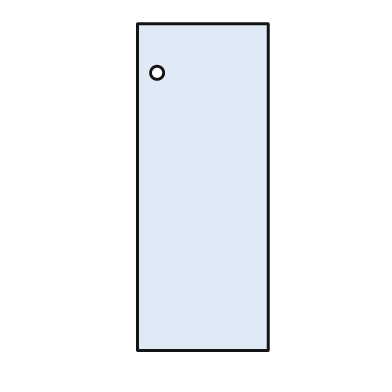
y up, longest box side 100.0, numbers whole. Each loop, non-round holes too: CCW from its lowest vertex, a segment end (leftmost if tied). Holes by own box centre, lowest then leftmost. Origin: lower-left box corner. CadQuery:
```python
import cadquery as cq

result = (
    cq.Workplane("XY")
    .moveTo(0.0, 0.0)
    .lineTo(40.0, 0.0)
    .lineTo(40.0, 100.0)
    .lineTo(0.0, 100.0)
    .close()
    .moveTo(6.0, 85.0)
    .circle(2.0)
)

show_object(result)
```